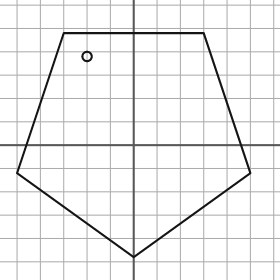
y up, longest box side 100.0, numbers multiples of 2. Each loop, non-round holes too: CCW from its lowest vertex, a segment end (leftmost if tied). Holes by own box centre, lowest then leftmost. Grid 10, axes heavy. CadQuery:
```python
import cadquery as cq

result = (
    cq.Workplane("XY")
    .moveTo(0.0, -48.0)
    .lineTo(50.0, -12.0)
    .lineTo(30.0, 48.0)
    .lineTo(-30.0, 48.0)
    .lineTo(-50.0, -12.0)
    .close()
    .moveTo(-20.0, 38.0)
    .circle(2.0)
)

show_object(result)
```